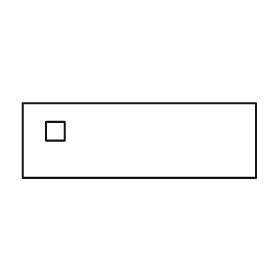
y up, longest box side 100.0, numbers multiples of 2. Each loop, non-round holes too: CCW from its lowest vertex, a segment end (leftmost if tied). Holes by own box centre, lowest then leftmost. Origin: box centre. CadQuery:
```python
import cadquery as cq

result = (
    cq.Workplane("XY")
    .moveTo(-50.0, -16.0)
    .lineTo(50.0, -16.0)
    .lineTo(50.0, 16.0)
    .lineTo(-50.0, 16.0)
    .close()
    .moveTo(-40.0, 0.0)
    .lineTo(-32.0, 0.0)
    .lineTo(-32.0, 8.0)
    .lineTo(-40.0, 8.0)
    .close()
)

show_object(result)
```